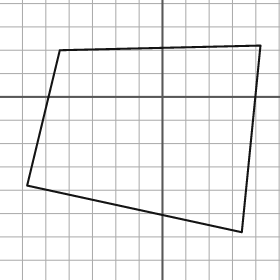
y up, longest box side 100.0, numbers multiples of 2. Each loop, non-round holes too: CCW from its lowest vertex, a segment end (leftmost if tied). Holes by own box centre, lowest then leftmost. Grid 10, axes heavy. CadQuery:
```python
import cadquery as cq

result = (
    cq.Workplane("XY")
    .moveTo(34.0, -58.0)
    .lineTo(42.0, 22.0)
    .lineTo(-44.0, 20.0)
    .lineTo(-58.0, -38.0)
    .close()
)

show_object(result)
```